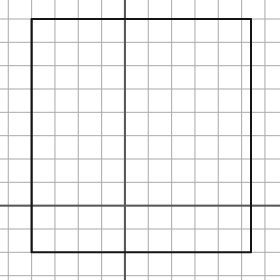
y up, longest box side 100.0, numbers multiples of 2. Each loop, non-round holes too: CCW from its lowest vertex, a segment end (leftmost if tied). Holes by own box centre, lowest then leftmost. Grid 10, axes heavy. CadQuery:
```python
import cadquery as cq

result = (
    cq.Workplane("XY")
    .moveTo(-40.0, -20.0)
    .lineTo(54.0, -20.0)
    .lineTo(54.0, 80.0)
    .lineTo(-40.0, 80.0)
    .close()
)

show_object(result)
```